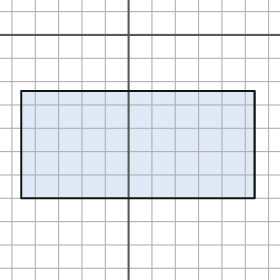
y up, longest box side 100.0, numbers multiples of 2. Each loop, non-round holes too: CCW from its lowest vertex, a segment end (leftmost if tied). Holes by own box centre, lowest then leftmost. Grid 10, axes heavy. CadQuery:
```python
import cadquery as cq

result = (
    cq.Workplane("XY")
    .moveTo(-46.0, -70.0)
    .lineTo(54.0, -70.0)
    .lineTo(54.0, -24.0)
    .lineTo(-46.0, -24.0)
    .close()
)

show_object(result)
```